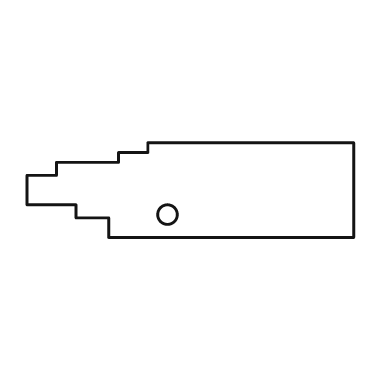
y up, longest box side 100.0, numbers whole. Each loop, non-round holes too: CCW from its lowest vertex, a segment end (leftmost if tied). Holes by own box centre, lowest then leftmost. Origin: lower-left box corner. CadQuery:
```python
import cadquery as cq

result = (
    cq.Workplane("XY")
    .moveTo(25.0, 0.0)
    .lineTo(100.0, 0.0)
    .lineTo(100.0, 29.0)
    .lineTo(37.0, 29.0)
    .lineTo(37.0, 26.0)
    .lineTo(28.0, 26.0)
    .lineTo(28.0, 23.0)
    .lineTo(9.0, 23.0)
    .lineTo(9.0, 19.0)
    .lineTo(0.0, 19.0)
    .lineTo(0.0, 10.0)
    .lineTo(15.0, 10.0)
    .lineTo(15.0, 6.0)
    .lineTo(25.0, 6.0)
    .close()
    .moveTo(43.0, 7.0)
    .circle(3.0)
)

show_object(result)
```